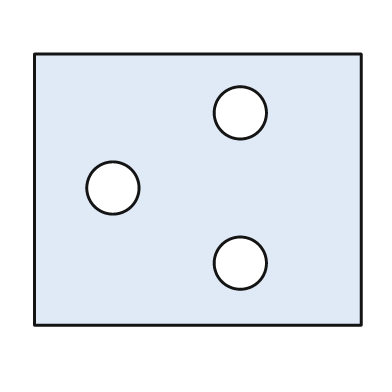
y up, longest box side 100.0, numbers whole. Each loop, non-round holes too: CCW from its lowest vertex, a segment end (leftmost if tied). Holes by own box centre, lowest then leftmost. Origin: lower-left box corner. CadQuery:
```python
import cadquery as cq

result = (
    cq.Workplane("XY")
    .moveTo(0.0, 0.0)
    .lineTo(100.0, 0.0)
    .lineTo(100.0, 83.0)
    .lineTo(0.0, 83.0)
    .close()
    .moveTo(63.0, 19.0)
    .circle(8.0)
    .moveTo(24.0, 42.0)
    .circle(8.0)
    .moveTo(63.0, 65.0)
    .circle(8.0)
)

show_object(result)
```